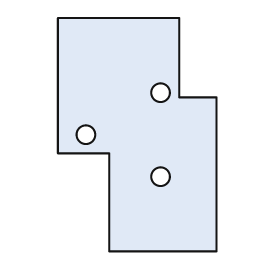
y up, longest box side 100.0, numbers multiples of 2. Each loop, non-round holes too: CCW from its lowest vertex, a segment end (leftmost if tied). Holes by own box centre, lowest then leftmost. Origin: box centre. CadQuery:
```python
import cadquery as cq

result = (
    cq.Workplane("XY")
    .moveTo(-12.0, -50.0)
    .lineTo(34.0, -50.0)
    .lineTo(34.0, 16.0)
    .lineTo(18.0, 16.0)
    .lineTo(18.0, 50.0)
    .lineTo(-34.0, 50.0)
    .lineTo(-34.0, -8.0)
    .lineTo(-12.0, -8.0)
    .close()
    .moveTo(10.0, -18.0)
    .circle(4.0)
    .moveTo(-22.0, 0.0)
    .circle(4.0)
    .moveTo(10.0, 18.0)
    .circle(4.0)
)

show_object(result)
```